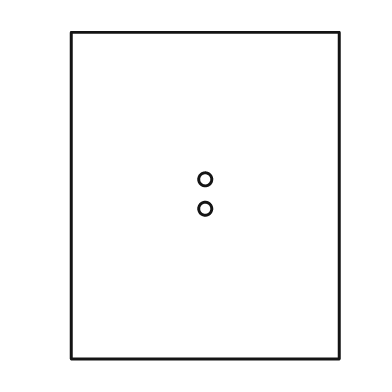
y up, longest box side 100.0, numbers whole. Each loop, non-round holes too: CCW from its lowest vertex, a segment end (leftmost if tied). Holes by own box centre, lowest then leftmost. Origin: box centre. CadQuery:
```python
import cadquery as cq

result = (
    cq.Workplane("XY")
    .moveTo(-41.0, -50.0)
    .lineTo(41.0, -50.0)
    .lineTo(41.0, 50.0)
    .lineTo(-41.0, 50.0)
    .close()
    .moveTo(0.0, -4.0)
    .circle(2.0)
    .moveTo(0.0, 5.0)
    .circle(2.0)
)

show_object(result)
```